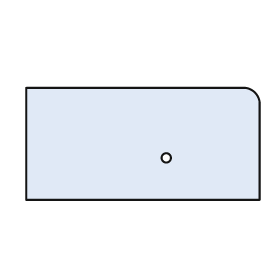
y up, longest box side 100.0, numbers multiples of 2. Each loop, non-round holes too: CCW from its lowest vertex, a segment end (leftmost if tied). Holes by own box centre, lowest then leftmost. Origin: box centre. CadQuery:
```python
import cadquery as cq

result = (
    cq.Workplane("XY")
    .moveTo(-50.0, -24.0)
    .lineTo(50.0, -24.0)
    .lineTo(50.0, 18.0)
    .threePointArc((48.0, 22.0), (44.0, 24.0))
    .lineTo(-50.0, 24.0)
    .close()
    .moveTo(10.0, -6.0)
    .circle(2.0)
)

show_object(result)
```